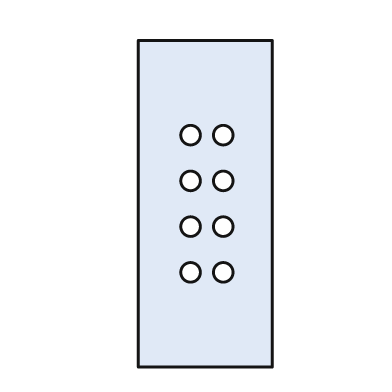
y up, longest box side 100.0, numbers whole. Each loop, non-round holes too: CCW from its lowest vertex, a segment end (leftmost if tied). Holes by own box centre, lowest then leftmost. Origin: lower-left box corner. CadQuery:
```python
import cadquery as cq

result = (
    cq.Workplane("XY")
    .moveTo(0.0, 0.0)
    .lineTo(41.0, 0.0)
    .lineTo(41.0, 100.0)
    .lineTo(0.0, 100.0)
    .close()
    .moveTo(16.0, 29.0)
    .circle(3.0)
    .moveTo(26.0, 29.0)
    .circle(3.0)
    .moveTo(16.0, 43.0)
    .circle(3.0)
    .moveTo(26.0, 43.0)
    .circle(3.0)
    .moveTo(16.0, 57.0)
    .circle(3.0)
    .moveTo(26.0, 57.0)
    .circle(3.0)
    .moveTo(16.0, 71.0)
    .circle(3.0)
    .moveTo(26.0, 71.0)
    .circle(3.0)
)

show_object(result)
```